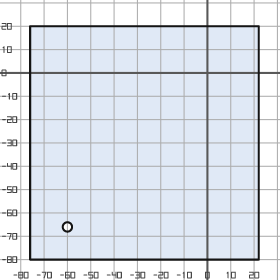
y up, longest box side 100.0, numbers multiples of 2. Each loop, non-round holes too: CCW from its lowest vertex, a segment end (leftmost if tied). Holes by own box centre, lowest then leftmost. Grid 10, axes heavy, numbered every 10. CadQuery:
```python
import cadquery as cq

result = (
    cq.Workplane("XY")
    .moveTo(-76.0, -80.0)
    .lineTo(22.0, -80.0)
    .lineTo(22.0, 20.0)
    .lineTo(-76.0, 20.0)
    .close()
    .moveTo(-60.0, -66.0)
    .circle(2.0)
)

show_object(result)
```